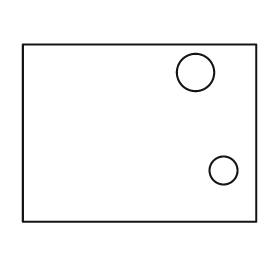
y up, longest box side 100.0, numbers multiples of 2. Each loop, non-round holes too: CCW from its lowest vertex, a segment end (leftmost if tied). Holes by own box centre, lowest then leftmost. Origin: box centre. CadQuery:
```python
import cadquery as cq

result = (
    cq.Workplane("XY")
    .moveTo(-50.0, -38.0)
    .lineTo(50.0, -38.0)
    .lineTo(50.0, 38.0)
    .lineTo(-50.0, 38.0)
    .close()
    .moveTo(36.0, -16.0)
    .circle(6.0)
    .moveTo(24.0, 26.0)
    .circle(8.0)
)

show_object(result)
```